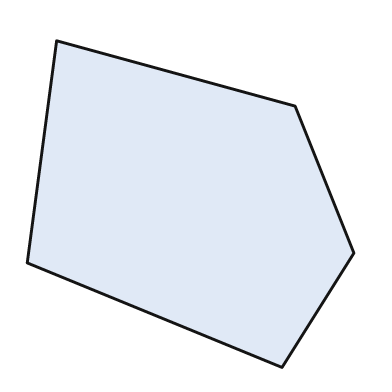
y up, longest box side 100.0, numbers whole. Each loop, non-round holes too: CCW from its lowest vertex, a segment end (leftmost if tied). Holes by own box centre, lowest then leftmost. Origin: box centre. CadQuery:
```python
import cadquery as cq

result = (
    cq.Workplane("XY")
    .moveTo(28.0, -50.0)
    .lineTo(50.0, -15.0)
    .lineTo(32.0, 30.0)
    .lineTo(-41.0, 50.0)
    .lineTo(-50.0, -18.0)
    .close()
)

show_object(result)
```